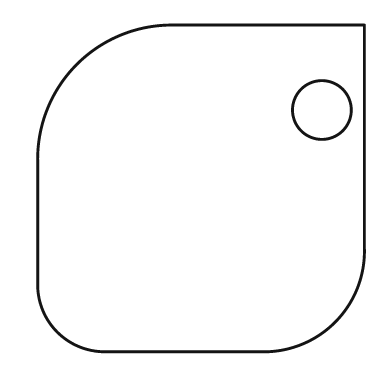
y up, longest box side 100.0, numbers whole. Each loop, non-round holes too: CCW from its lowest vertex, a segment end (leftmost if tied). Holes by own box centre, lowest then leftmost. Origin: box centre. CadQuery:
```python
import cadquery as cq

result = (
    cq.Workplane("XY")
    .moveTo(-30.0, -50.0)
    .lineTo(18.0, -50.0)
    .threePointArc((41.0, -41.0), (50.0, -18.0))
    .lineTo(50.0, 50.0)
    .lineTo(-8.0, 50.0)
    .threePointArc((-38.0, 38.0), (-50.0, 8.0))
    .lineTo(-50.0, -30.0)
    .threePointArc((-44.0, -44.0), (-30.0, -50.0))
    .close()
    .moveTo(37.0, 24.0)
    .circle(9.0)
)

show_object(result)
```